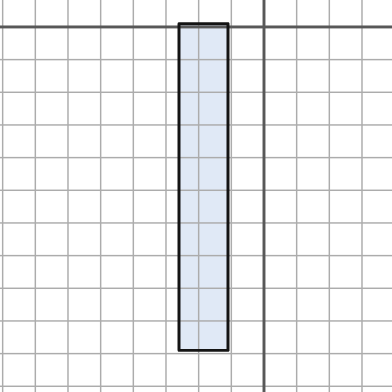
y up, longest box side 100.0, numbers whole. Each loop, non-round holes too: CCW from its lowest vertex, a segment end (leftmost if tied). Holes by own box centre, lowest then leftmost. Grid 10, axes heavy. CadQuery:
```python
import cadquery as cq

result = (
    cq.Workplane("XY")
    .moveTo(-26.0, -99.0)
    .lineTo(-11.0, -99.0)
    .lineTo(-11.0, 1.0)
    .lineTo(-26.0, 1.0)
    .close()
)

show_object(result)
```